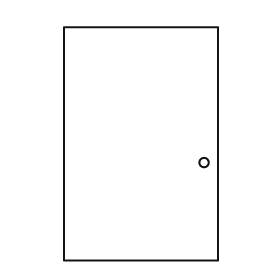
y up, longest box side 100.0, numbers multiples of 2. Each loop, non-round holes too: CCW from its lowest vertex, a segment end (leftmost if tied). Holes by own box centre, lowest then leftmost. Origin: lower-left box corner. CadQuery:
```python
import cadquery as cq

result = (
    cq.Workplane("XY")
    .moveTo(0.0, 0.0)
    .lineTo(66.0, 0.0)
    .lineTo(66.0, 100.0)
    .lineTo(0.0, 100.0)
    .close()
    .moveTo(60.0, 42.0)
    .circle(2.0)
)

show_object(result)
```